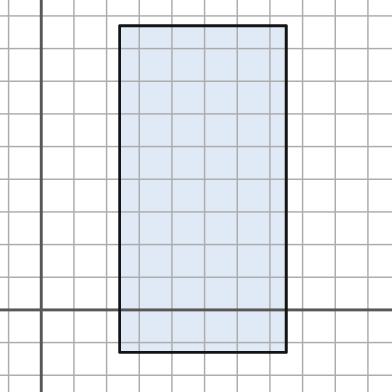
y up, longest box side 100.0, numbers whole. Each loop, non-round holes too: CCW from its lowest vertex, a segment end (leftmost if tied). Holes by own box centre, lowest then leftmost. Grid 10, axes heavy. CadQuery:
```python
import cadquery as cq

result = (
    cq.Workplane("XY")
    .moveTo(24.0, -13.0)
    .lineTo(75.0, -13.0)
    .lineTo(75.0, 87.0)
    .lineTo(24.0, 87.0)
    .close()
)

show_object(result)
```